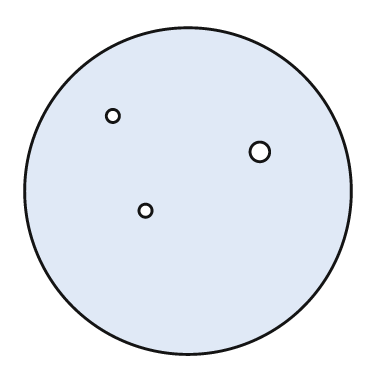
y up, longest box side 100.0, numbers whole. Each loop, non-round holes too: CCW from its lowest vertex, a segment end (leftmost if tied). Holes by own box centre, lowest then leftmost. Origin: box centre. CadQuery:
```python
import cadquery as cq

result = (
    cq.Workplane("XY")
    .moveTo(0.0, 0.0)
    .circle(50.0)
    .moveTo(-13.0, -6.0)
    .circle(2.0)
    .moveTo(22.0, 12.0)
    .circle(3.0)
    .moveTo(-23.0, 23.0)
    .circle(2.0)
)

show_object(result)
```